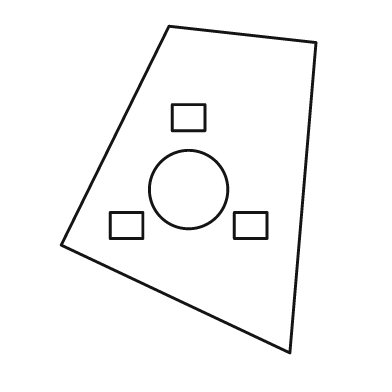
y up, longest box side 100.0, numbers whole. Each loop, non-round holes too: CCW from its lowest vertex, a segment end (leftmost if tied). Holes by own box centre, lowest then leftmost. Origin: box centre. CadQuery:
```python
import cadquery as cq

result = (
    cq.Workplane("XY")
    .moveTo(31.0, -50.0)
    .lineTo(39.0, 45.0)
    .lineTo(-6.0, 50.0)
    .lineTo(-39.0, -17.0)
    .close()
    .moveTo(-24.0, -15.0)
    .lineTo(-14.0, -15.0)
    .lineTo(-14.0, -7.0)
    .lineTo(-24.0, -7.0)
    .close()
    .moveTo(14.0, -15.0)
    .lineTo(24.0, -15.0)
    .lineTo(24.0, -7.0)
    .lineTo(14.0, -7.0)
    .close()
    .moveTo(0.0, 0.0)
    .circle(12.0)
    .moveTo(-5.0, 18.0)
    .lineTo(5.0, 18.0)
    .lineTo(5.0, 26.0)
    .lineTo(-5.0, 26.0)
    .close()
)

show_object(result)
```